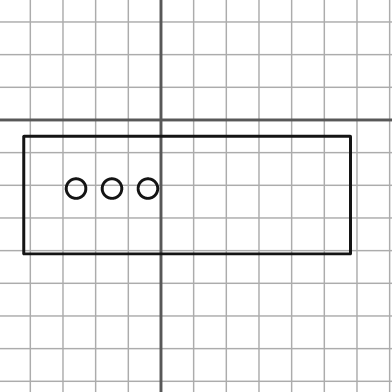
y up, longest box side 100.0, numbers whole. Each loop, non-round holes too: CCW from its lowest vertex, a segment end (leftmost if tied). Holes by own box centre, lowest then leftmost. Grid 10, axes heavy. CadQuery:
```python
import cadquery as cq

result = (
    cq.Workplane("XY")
    .moveTo(-42.0, -41.0)
    .lineTo(58.0, -41.0)
    .lineTo(58.0, -5.0)
    .lineTo(-42.0, -5.0)
    .close()
    .moveTo(-26.0, -21.0)
    .circle(3.0)
    .moveTo(-15.0, -21.0)
    .circle(3.0)
    .moveTo(-4.0, -21.0)
    .circle(3.0)
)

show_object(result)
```